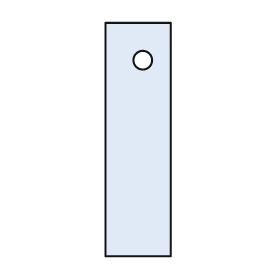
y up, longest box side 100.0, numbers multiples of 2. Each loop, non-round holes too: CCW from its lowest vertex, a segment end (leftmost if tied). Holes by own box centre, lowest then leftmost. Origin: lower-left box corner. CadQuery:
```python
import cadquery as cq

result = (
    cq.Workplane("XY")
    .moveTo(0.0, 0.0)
    .lineTo(28.0, 0.0)
    .lineTo(28.0, 100.0)
    .lineTo(0.0, 100.0)
    .close()
    .moveTo(16.0, 84.0)
    .circle(4.0)
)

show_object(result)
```